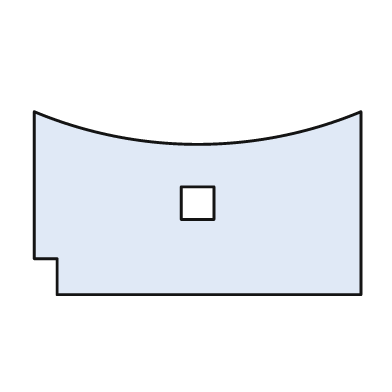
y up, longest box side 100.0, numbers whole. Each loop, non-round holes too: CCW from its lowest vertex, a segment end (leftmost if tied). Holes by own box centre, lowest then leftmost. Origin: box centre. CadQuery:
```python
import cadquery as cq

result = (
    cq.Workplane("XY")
    .moveTo(-43.0, -28.0)
    .lineTo(50.0, -28.0)
    .lineTo(50.0, 28.0)
    .threePointArc((0.0, 18.0), (-50.0, 28.0))
    .lineTo(-50.0, -17.0)
    .lineTo(-43.0, -17.0)
    .close()
    .moveTo(-5.0, -5.0)
    .lineTo(5.0, -5.0)
    .lineTo(5.0, 5.0)
    .lineTo(-5.0, 5.0)
    .close()
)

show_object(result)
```